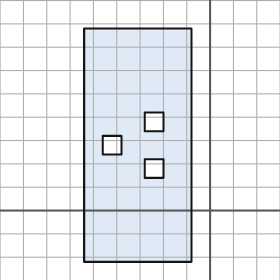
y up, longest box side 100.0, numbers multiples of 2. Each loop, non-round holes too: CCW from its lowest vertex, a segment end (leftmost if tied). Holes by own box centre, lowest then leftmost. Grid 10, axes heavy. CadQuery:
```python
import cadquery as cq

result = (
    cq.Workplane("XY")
    .moveTo(-54.0, -22.0)
    .lineTo(-8.0, -22.0)
    .lineTo(-8.0, 78.0)
    .lineTo(-54.0, 78.0)
    .close()
    .moveTo(-28.0, 14.0)
    .lineTo(-20.0, 14.0)
    .lineTo(-20.0, 22.0)
    .lineTo(-28.0, 22.0)
    .close()
    .moveTo(-46.0, 24.0)
    .lineTo(-38.0, 24.0)
    .lineTo(-38.0, 32.0)
    .lineTo(-46.0, 32.0)
    .close()
    .moveTo(-28.0, 34.0)
    .lineTo(-20.0, 34.0)
    .lineTo(-20.0, 42.0)
    .lineTo(-28.0, 42.0)
    .close()
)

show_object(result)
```